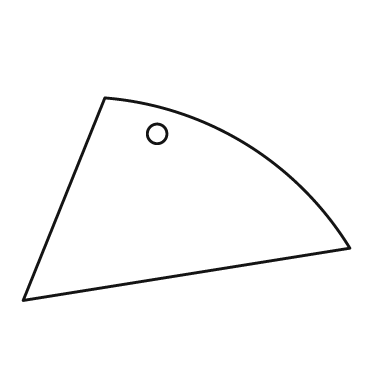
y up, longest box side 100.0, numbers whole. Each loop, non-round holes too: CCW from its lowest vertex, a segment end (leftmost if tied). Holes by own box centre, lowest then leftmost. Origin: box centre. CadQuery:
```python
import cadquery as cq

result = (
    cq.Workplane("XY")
    .moveTo(-50.0, -31.0)
    .lineTo(50.0, -15.0)
    .threePointArc((18.0, 17.0), (-25.0, 31.0))
    .close()
    .moveTo(-9.0, 20.0)
    .circle(3.0)
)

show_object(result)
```